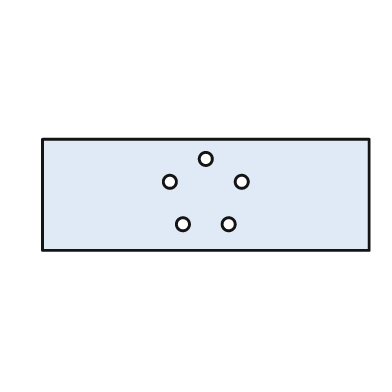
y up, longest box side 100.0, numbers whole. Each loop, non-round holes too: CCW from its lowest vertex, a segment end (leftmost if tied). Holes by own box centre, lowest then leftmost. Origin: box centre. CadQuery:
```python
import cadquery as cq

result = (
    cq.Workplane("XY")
    .moveTo(-50.0, -17.0)
    .lineTo(50.0, -17.0)
    .lineTo(50.0, 17.0)
    .lineTo(-50.0, 17.0)
    .close()
    .moveTo(-7.0, -9.0)
    .circle(2.0)
    .moveTo(7.0, -9.0)
    .circle(2.0)
    .moveTo(-11.0, 4.0)
    .circle(2.0)
    .moveTo(11.0, 4.0)
    .circle(2.0)
    .moveTo(0.0, 11.0)
    .circle(2.0)
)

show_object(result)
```